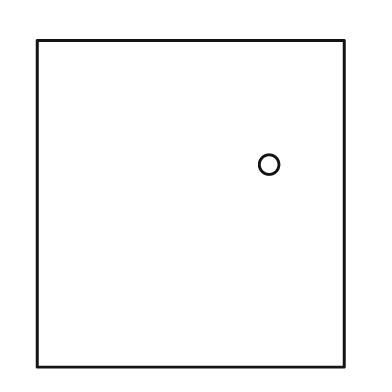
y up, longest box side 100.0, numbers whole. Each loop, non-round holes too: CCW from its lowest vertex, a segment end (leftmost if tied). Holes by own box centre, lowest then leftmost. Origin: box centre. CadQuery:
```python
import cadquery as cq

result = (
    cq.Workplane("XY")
    .moveTo(-47.0, -50.0)
    .lineTo(47.0, -50.0)
    .lineTo(47.0, 50.0)
    .lineTo(-47.0, 50.0)
    .close()
    .moveTo(24.0, 12.0)
    .circle(3.0)
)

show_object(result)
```